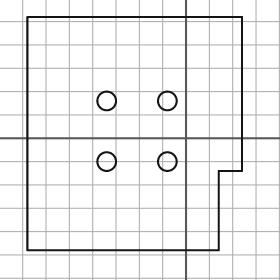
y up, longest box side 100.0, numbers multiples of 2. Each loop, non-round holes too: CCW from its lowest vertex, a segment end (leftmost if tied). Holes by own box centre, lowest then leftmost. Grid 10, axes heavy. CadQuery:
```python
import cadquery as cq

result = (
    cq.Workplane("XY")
    .moveTo(-68.0, -48.0)
    .lineTo(14.0, -48.0)
    .lineTo(14.0, -14.0)
    .lineTo(24.0, -14.0)
    .lineTo(24.0, 52.0)
    .lineTo(-68.0, 52.0)
    .close()
    .moveTo(-34.0, -10.0)
    .circle(4.0)
    .moveTo(-8.0, -10.0)
    .circle(4.0)
    .moveTo(-34.0, 16.0)
    .circle(4.0)
    .moveTo(-8.0, 16.0)
    .circle(4.0)
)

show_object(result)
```